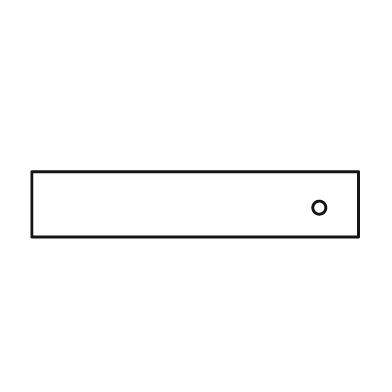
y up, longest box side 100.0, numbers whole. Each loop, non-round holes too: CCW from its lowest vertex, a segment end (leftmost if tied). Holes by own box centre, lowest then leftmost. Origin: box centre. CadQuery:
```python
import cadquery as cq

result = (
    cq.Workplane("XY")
    .moveTo(-50.0, -10.0)
    .lineTo(50.0, -10.0)
    .lineTo(50.0, 10.0)
    .lineTo(-50.0, 10.0)
    .close()
    .moveTo(38.0, -1.0)
    .circle(2.0)
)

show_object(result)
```